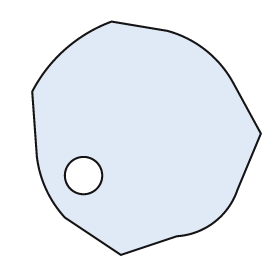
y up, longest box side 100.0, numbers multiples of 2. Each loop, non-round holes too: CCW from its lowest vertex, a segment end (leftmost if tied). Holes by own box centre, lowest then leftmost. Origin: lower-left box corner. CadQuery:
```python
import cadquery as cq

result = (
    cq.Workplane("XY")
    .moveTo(38.0, 0.0)
    .lineTo(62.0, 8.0)
    .threePointArc((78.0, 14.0), (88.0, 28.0))
    .lineTo(98.0, 52.0)
    .lineTo(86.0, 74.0)
    .threePointArc((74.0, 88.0), (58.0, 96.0))
    .lineTo(34.0, 100.0)
    .threePointArc((14.0, 88.0), (0.0, 70.0))
    .lineTo(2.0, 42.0)
    .threePointArc((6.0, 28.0), (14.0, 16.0))
    .close()
    .moveTo(22.0, 34.0)
    .circle(8.0)
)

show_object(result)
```